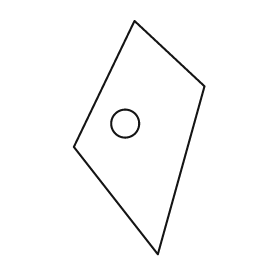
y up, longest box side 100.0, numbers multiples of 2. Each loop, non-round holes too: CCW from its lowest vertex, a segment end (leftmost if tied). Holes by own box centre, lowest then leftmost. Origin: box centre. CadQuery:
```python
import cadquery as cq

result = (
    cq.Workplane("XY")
    .moveTo(8.0, -50.0)
    .lineTo(28.0, 22.0)
    .lineTo(-2.0, 50.0)
    .lineTo(-28.0, -4.0)
    .close()
    .moveTo(-6.0, 6.0)
    .circle(6.0)
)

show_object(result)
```